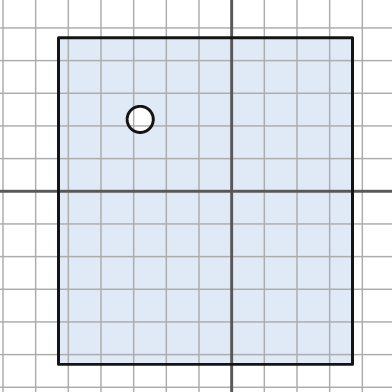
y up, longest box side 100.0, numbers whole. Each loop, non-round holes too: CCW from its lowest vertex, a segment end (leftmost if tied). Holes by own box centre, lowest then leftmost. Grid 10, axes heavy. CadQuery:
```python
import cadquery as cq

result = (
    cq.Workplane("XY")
    .moveTo(-53.0, -53.0)
    .lineTo(37.0, -53.0)
    .lineTo(37.0, 47.0)
    .lineTo(-53.0, 47.0)
    .close()
    .moveTo(-28.0, 22.0)
    .circle(4.0)
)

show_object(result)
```